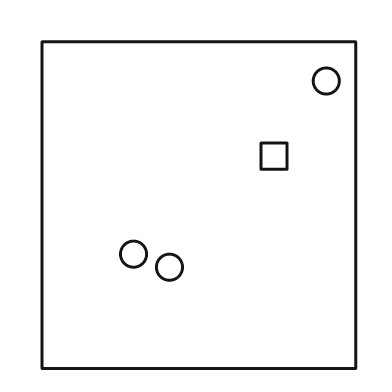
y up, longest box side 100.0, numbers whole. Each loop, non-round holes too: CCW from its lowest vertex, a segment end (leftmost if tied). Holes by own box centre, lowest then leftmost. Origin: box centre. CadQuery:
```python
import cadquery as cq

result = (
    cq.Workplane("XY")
    .moveTo(-48.0, -50.0)
    .lineTo(48.0, -50.0)
    .lineTo(48.0, 50.0)
    .lineTo(-48.0, 50.0)
    .close()
    .moveTo(-9.0, -19.0)
    .circle(4.0)
    .moveTo(-20.0, -15.0)
    .circle(4.0)
    .moveTo(19.0, 11.0)
    .lineTo(27.0, 11.0)
    .lineTo(27.0, 19.0)
    .lineTo(19.0, 19.0)
    .close()
    .moveTo(39.0, 38.0)
    .circle(4.0)
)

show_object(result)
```